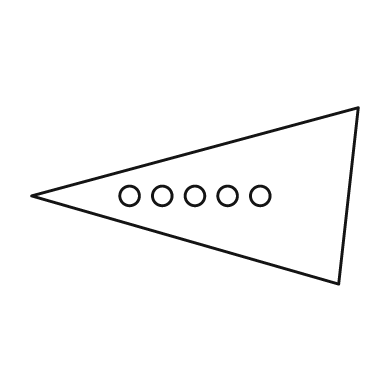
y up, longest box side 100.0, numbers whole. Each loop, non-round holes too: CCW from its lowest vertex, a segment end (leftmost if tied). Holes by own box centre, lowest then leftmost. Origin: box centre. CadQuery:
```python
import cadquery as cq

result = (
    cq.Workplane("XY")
    .moveTo(44.0, -27.0)
    .lineTo(50.0, 27.0)
    .lineTo(-50.0, 0.0)
    .close()
    .moveTo(-20.0, 0.0)
    .circle(3.0)
    .moveTo(-10.0, 0.0)
    .circle(3.0)
    .moveTo(0.0, 0.0)
    .circle(3.0)
    .moveTo(10.0, 0.0)
    .circle(3.0)
    .moveTo(20.0, 0.0)
    .circle(3.0)
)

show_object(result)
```